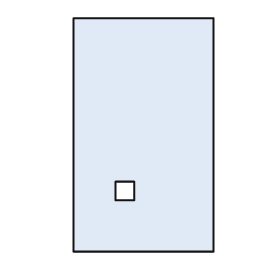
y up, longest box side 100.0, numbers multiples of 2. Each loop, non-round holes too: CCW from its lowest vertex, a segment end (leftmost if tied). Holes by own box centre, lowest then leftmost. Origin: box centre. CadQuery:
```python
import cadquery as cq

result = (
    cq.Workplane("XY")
    .moveTo(-30.0, -50.0)
    .lineTo(30.0, -50.0)
    .lineTo(30.0, 50.0)
    .lineTo(-30.0, 50.0)
    .close()
    .moveTo(-12.0, -28.0)
    .lineTo(-4.0, -28.0)
    .lineTo(-4.0, -20.0)
    .lineTo(-12.0, -20.0)
    .close()
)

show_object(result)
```